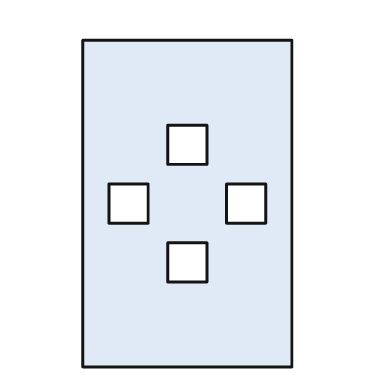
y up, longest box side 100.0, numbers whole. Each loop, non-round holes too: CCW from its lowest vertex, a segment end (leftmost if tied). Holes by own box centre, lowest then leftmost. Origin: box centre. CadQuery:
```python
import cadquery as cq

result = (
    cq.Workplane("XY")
    .moveTo(-32.0, -50.0)
    .lineTo(32.0, -50.0)
    .lineTo(32.0, 50.0)
    .lineTo(-32.0, 50.0)
    .close()
    .moveTo(-6.0, -24.0)
    .lineTo(6.0, -24.0)
    .lineTo(6.0, -12.0)
    .lineTo(-6.0, -12.0)
    .close()
    .moveTo(-24.0, -6.0)
    .lineTo(-12.0, -6.0)
    .lineTo(-12.0, 6.0)
    .lineTo(-24.0, 6.0)
    .close()
    .moveTo(12.0, -6.0)
    .lineTo(24.0, -6.0)
    .lineTo(24.0, 6.0)
    .lineTo(12.0, 6.0)
    .close()
    .moveTo(-6.0, 12.0)
    .lineTo(6.0, 12.0)
    .lineTo(6.0, 24.0)
    .lineTo(-6.0, 24.0)
    .close()
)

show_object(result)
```